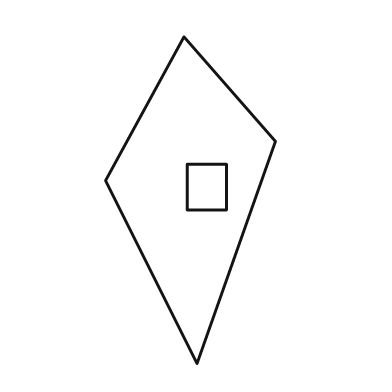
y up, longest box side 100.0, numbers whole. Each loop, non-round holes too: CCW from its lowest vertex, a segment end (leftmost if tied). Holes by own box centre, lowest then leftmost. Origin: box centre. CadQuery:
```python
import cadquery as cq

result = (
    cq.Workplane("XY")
    .moveTo(2.0, -50.0)
    .lineTo(26.0, 18.0)
    .lineTo(-2.0, 50.0)
    .lineTo(-26.0, 6.0)
    .close()
    .moveTo(-1.0, -3.0)
    .lineTo(11.0, -3.0)
    .lineTo(11.0, 11.0)
    .lineTo(-1.0, 11.0)
    .close()
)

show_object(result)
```